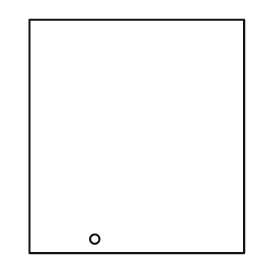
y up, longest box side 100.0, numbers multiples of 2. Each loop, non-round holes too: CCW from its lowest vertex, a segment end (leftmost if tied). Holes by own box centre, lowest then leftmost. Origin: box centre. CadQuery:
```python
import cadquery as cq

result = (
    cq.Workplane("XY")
    .moveTo(-46.0, -50.0)
    .lineTo(46.0, -50.0)
    .lineTo(46.0, 50.0)
    .lineTo(-46.0, 50.0)
    .close()
    .moveTo(-18.0, -44.0)
    .circle(2.0)
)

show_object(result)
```